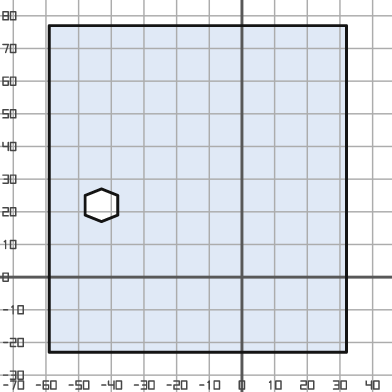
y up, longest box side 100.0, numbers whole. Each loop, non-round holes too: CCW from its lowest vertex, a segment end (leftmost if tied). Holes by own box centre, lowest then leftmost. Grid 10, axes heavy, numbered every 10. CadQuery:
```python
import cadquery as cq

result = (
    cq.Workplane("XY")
    .moveTo(-59.0, -23.0)
    .lineTo(32.0, -23.0)
    .lineTo(32.0, 77.0)
    .lineTo(-59.0, 77.0)
    .close()
    .moveTo(-43.0, 17.0)
    .lineTo(-38.0, 19.0)
    .lineTo(-38.0, 25.0)
    .lineTo(-43.0, 27.0)
    .lineTo(-48.0, 25.0)
    .lineTo(-48.0, 19.0)
    .close()
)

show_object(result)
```